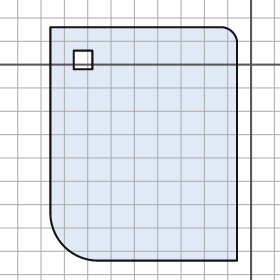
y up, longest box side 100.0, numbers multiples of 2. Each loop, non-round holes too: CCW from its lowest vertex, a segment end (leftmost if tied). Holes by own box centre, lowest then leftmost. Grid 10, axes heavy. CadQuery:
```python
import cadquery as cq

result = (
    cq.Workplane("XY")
    .moveTo(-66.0, -84.0)
    .lineTo(-6.0, -84.0)
    .lineTo(-6.0, 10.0)
    .threePointArc((-8.0, 14.0), (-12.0, 16.0))
    .lineTo(-86.0, 16.0)
    .lineTo(-86.0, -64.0)
    .threePointArc((-80.0, -78.0), (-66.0, -84.0))
    .close()
    .moveTo(-76.0, -2.0)
    .lineTo(-68.0, -2.0)
    .lineTo(-68.0, 6.0)
    .lineTo(-76.0, 6.0)
    .close()
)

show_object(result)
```